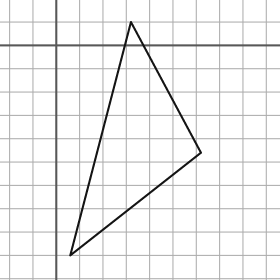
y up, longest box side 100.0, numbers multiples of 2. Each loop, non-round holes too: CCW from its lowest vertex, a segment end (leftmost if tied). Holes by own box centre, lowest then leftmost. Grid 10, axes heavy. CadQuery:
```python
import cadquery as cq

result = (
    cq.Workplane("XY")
    .moveTo(6.0, -90.0)
    .lineTo(62.0, -46.0)
    .lineTo(32.0, 10.0)
    .close()
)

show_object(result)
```